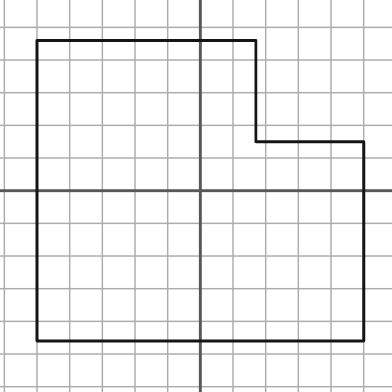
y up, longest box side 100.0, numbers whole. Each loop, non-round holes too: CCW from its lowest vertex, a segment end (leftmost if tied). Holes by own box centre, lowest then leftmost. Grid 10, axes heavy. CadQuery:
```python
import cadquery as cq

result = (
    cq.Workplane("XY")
    .moveTo(-50.0, -46.0)
    .lineTo(50.0, -46.0)
    .lineTo(50.0, 15.0)
    .lineTo(17.0, 15.0)
    .lineTo(17.0, 46.0)
    .lineTo(-50.0, 46.0)
    .close()
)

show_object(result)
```